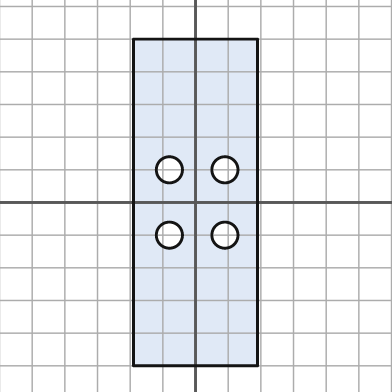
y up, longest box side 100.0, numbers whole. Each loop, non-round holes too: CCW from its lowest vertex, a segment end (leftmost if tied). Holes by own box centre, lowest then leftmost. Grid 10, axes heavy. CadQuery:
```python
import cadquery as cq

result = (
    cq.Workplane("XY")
    .moveTo(-19.0, -50.0)
    .lineTo(19.0, -50.0)
    .lineTo(19.0, 50.0)
    .lineTo(-19.0, 50.0)
    .close()
    .moveTo(-8.0, -10.0)
    .circle(4.0)
    .moveTo(9.0, -10.0)
    .circle(4.0)
    .moveTo(-8.0, 10.0)
    .circle(4.0)
    .moveTo(9.0, 10.0)
    .circle(4.0)
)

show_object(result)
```